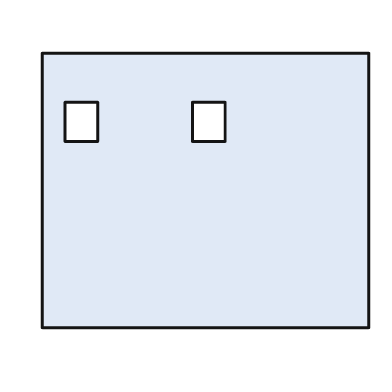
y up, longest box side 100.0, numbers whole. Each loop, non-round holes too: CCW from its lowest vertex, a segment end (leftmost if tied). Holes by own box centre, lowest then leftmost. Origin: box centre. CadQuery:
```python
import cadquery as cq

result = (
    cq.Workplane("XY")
    .moveTo(-50.0, -42.0)
    .lineTo(50.0, -42.0)
    .lineTo(50.0, 42.0)
    .lineTo(-50.0, 42.0)
    .close()
    .moveTo(-43.0, 15.0)
    .lineTo(-33.0, 15.0)
    .lineTo(-33.0, 27.0)
    .lineTo(-43.0, 27.0)
    .close()
    .moveTo(-4.0, 15.0)
    .lineTo(6.0, 15.0)
    .lineTo(6.0, 27.0)
    .lineTo(-4.0, 27.0)
    .close()
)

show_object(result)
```